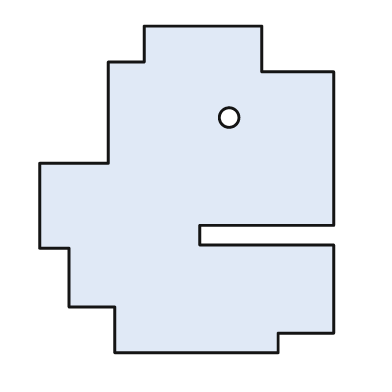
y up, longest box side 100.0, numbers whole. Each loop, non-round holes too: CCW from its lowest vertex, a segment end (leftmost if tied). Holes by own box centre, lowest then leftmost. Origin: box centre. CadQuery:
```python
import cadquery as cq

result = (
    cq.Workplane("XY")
    .moveTo(-22.0, -50.0)
    .lineTo(28.0, -50.0)
    .lineTo(28.0, -44.0)
    .lineTo(45.0, -44.0)
    .lineTo(45.0, -17.0)
    .lineTo(4.0, -17.0)
    .lineTo(4.0, -11.0)
    .lineTo(45.0, -11.0)
    .lineTo(45.0, 36.0)
    .lineTo(23.0, 36.0)
    .lineTo(23.0, 50.0)
    .lineTo(-13.0, 50.0)
    .lineTo(-13.0, 39.0)
    .lineTo(-24.0, 39.0)
    .lineTo(-24.0, 8.0)
    .lineTo(-45.0, 8.0)
    .lineTo(-45.0, -18.0)
    .lineTo(-36.0, -18.0)
    .lineTo(-36.0, -36.0)
    .lineTo(-22.0, -36.0)
    .close()
    .moveTo(13.0, 22.0)
    .circle(3.0)
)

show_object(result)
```